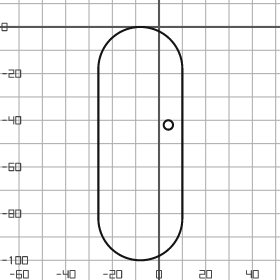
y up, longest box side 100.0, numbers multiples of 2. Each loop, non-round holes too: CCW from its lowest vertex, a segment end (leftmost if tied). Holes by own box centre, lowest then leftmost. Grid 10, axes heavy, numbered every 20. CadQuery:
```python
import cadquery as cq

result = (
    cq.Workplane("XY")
    .moveTo(-26.0, -82.0)
    .threePointArc((-8.0, -100.0), (10.0, -82.0))
    .lineTo(10.0, -18.0)
    .threePointArc((-8.0, 0.0), (-26.0, -18.0))
    .close()
    .moveTo(4.0, -42.0)
    .circle(2.0)
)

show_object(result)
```